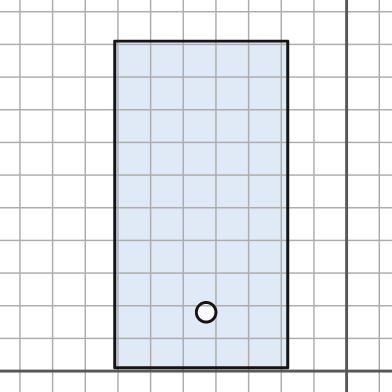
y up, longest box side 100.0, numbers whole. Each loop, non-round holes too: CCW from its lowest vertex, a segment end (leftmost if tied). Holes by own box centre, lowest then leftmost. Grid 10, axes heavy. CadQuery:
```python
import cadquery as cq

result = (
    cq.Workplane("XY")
    .moveTo(-71.0, 1.0)
    .lineTo(-18.0, 1.0)
    .lineTo(-18.0, 101.0)
    .lineTo(-71.0, 101.0)
    .close()
    .moveTo(-43.0, 18.0)
    .circle(3.0)
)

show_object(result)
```